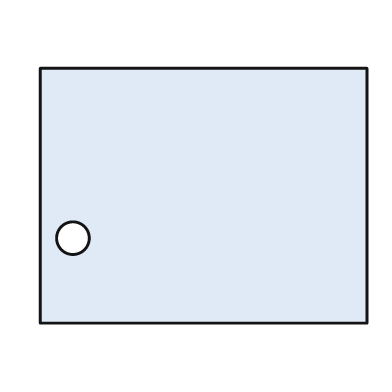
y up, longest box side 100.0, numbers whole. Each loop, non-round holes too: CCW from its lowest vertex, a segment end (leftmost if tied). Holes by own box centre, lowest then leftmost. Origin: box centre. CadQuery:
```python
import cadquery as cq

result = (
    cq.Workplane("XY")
    .moveTo(-50.0, -39.0)
    .lineTo(50.0, -39.0)
    .lineTo(50.0, 39.0)
    .lineTo(-50.0, 39.0)
    .close()
    .moveTo(-40.0, -13.0)
    .circle(5.0)
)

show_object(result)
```